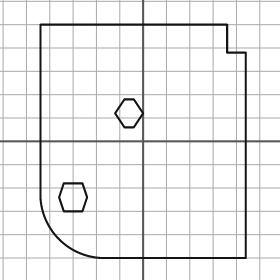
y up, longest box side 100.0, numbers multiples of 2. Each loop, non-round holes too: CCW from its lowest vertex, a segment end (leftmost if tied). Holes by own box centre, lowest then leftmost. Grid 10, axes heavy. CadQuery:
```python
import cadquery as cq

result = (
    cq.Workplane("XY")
    .moveTo(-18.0, -50.0)
    .lineTo(44.0, -50.0)
    .lineTo(44.0, 38.0)
    .lineTo(36.0, 38.0)
    .lineTo(36.0, 50.0)
    .lineTo(-44.0, 50.0)
    .lineTo(-44.0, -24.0)
    .threePointArc((-36.0, -42.0), (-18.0, -50.0))
    .close()
    .moveTo(-34.0, -30.0)
    .lineTo(-26.0, -30.0)
    .lineTo(-24.0, -24.0)
    .lineTo(-26.0, -18.0)
    .lineTo(-34.0, -18.0)
    .lineTo(-36.0, -24.0)
    .close()
    .moveTo(-8.0, 6.0)
    .lineTo(-4.0, 6.0)
    .lineTo(0.0, 12.0)
    .lineTo(-4.0, 18.0)
    .lineTo(-8.0, 18.0)
    .lineTo(-12.0, 12.0)
    .close()
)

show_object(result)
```